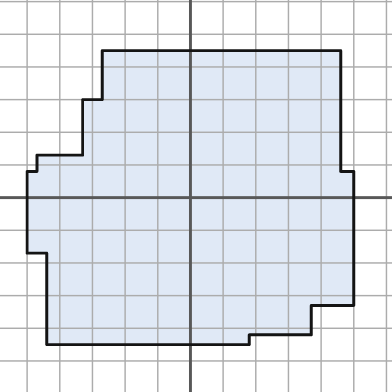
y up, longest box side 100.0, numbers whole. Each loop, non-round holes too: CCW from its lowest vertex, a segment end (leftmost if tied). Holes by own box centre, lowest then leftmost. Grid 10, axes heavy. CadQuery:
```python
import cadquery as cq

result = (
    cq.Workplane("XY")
    .moveTo(-44.0, -45.0)
    .lineTo(18.0, -45.0)
    .lineTo(18.0, -42.0)
    .lineTo(37.0, -42.0)
    .lineTo(37.0, -33.0)
    .lineTo(50.0, -33.0)
    .lineTo(50.0, 8.0)
    .lineTo(46.0, 8.0)
    .lineTo(46.0, 45.0)
    .lineTo(-27.0, 45.0)
    .lineTo(-27.0, 30.0)
    .lineTo(-33.0, 30.0)
    .lineTo(-33.0, 13.0)
    .lineTo(-47.0, 13.0)
    .lineTo(-47.0, 8.0)
    .lineTo(-50.0, 8.0)
    .lineTo(-50.0, -17.0)
    .lineTo(-44.0, -17.0)
    .close()
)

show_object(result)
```